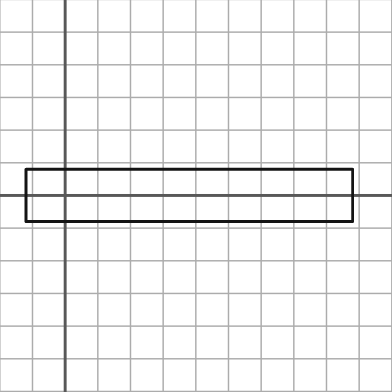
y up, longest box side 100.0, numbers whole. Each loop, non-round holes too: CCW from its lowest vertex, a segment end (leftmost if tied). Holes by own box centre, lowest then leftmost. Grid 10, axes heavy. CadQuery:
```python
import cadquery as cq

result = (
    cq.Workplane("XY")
    .moveTo(-12.0, -8.0)
    .lineTo(88.0, -8.0)
    .lineTo(88.0, 8.0)
    .lineTo(-12.0, 8.0)
    .close()
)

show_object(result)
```